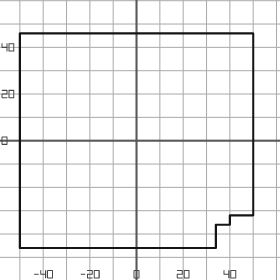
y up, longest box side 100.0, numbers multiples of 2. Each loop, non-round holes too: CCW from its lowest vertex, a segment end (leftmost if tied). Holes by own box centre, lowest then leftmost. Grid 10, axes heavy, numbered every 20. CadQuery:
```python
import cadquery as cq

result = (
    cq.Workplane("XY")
    .moveTo(-50.0, -46.0)
    .lineTo(34.0, -46.0)
    .lineTo(34.0, -36.0)
    .lineTo(40.0, -36.0)
    .lineTo(40.0, -32.0)
    .lineTo(50.0, -32.0)
    .lineTo(50.0, 46.0)
    .lineTo(-50.0, 46.0)
    .close()
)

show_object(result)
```